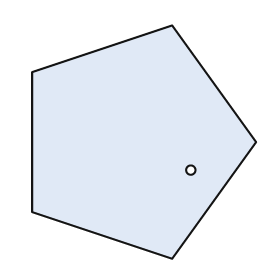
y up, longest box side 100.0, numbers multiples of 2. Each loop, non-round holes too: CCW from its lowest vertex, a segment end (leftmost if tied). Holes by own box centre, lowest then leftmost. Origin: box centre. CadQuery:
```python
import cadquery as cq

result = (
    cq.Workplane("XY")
    .moveTo(12.0, -50.0)
    .lineTo(48.0, 0.0)
    .lineTo(12.0, 50.0)
    .lineTo(-48.0, 30.0)
    .lineTo(-48.0, -30.0)
    .close()
    .moveTo(20.0, -12.0)
    .circle(2.0)
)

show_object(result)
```